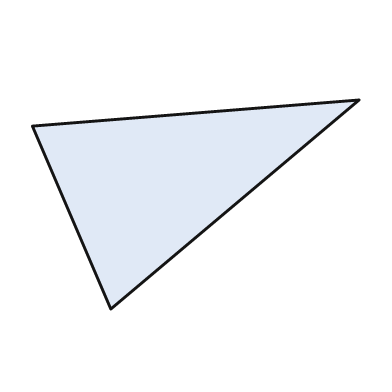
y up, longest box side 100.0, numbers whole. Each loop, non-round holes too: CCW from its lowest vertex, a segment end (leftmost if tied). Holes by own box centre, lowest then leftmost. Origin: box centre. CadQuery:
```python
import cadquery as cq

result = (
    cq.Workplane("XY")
    .moveTo(-26.0, -32.0)
    .lineTo(50.0, 32.0)
    .lineTo(-50.0, 24.0)
    .close()
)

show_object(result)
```